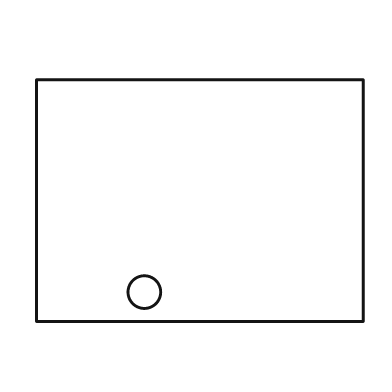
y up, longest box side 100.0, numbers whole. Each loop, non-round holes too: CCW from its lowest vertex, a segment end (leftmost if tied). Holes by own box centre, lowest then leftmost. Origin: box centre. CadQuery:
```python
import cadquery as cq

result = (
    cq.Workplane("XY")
    .moveTo(-50.0, -37.0)
    .lineTo(50.0, -37.0)
    .lineTo(50.0, 37.0)
    .lineTo(-50.0, 37.0)
    .close()
    .moveTo(-17.0, -28.0)
    .circle(5.0)
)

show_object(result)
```